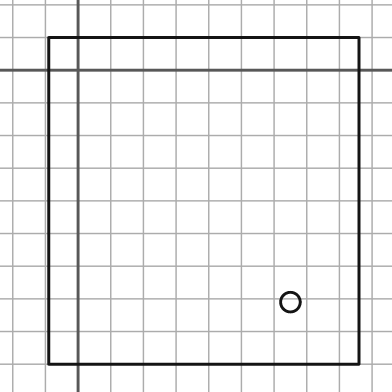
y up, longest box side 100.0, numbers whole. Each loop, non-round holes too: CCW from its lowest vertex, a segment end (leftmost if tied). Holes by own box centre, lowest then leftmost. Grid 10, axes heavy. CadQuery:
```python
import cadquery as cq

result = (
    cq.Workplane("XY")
    .moveTo(-9.0, -90.0)
    .lineTo(86.0, -90.0)
    .lineTo(86.0, 10.0)
    .lineTo(-9.0, 10.0)
    .close()
    .moveTo(65.0, -71.0)
    .circle(3.0)
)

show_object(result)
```